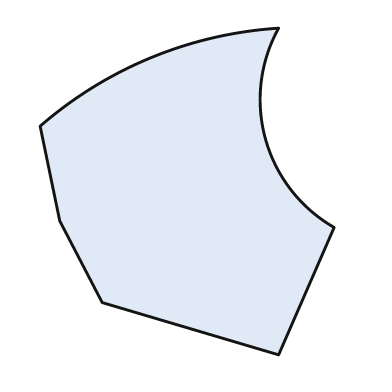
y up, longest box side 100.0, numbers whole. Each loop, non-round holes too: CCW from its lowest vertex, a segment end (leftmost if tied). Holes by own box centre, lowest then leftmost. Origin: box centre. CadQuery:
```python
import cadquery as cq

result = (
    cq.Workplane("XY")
    .moveTo(28.0, -50.0)
    .lineTo(45.0, -11.0)
    .threePointArc((24.0, 16.0), (28.0, 50.0))
    .threePointArc((-11.0, 41.0), (-45.0, 20.0))
    .lineTo(-39.0, -9.0)
    .lineTo(-26.0, -34.0)
    .close()
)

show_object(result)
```